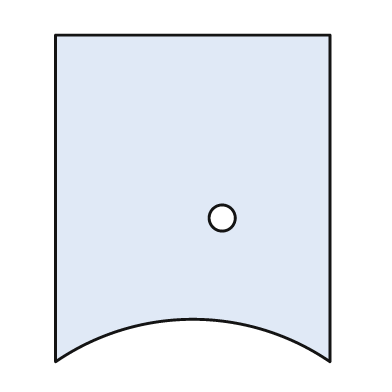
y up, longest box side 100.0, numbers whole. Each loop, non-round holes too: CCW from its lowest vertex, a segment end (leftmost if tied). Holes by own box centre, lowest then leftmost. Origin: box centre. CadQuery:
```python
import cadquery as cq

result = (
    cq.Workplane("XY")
    .moveTo(-42.0, -50.0)
    .threePointArc((0.0, -37.0), (42.0, -50.0))
    .lineTo(42.0, 50.0)
    .lineTo(-42.0, 50.0)
    .close()
    .moveTo(9.0, -6.0)
    .circle(4.0)
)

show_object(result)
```